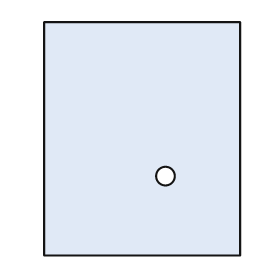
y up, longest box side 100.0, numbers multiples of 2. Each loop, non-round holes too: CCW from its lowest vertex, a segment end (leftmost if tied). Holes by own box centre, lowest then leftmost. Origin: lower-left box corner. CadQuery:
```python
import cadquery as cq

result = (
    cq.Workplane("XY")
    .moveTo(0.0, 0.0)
    .lineTo(84.0, 0.0)
    .lineTo(84.0, 100.0)
    .lineTo(0.0, 100.0)
    .close()
    .moveTo(52.0, 34.0)
    .circle(4.0)
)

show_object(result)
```